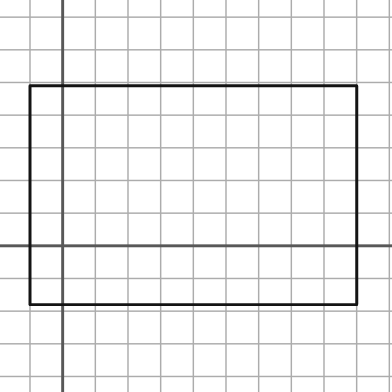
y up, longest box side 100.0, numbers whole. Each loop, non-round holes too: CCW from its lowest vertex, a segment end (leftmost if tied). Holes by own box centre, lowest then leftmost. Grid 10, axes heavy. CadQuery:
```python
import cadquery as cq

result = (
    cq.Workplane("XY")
    .moveTo(-10.0, -18.0)
    .lineTo(90.0, -18.0)
    .lineTo(90.0, 49.0)
    .lineTo(-10.0, 49.0)
    .close()
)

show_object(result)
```